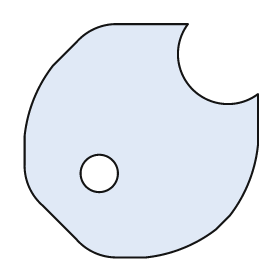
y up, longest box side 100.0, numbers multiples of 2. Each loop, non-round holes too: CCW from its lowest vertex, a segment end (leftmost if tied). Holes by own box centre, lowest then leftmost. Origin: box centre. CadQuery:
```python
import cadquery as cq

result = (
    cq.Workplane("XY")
    .moveTo(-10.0, -50.0)
    .lineTo(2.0, -50.0)
    .threePointArc((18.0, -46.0), (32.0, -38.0))
    .lineTo(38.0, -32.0)
    .threePointArc((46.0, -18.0), (50.0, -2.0))
    .lineTo(50.0, 20.0)
    .threePointArc((22.0, 22.0), (20.0, 50.0))
    .lineTo(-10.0, 50.0)
    .threePointArc((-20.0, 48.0), (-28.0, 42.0))
    .lineTo(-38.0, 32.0)
    .threePointArc((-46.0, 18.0), (-50.0, 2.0))
    .lineTo(-50.0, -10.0)
    .threePointArc((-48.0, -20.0), (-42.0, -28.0))
    .lineTo(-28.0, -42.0)
    .threePointArc((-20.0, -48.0), (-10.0, -50.0))
    .close()
    .moveTo(-18.0, -14.0)
    .circle(8.0)
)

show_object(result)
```